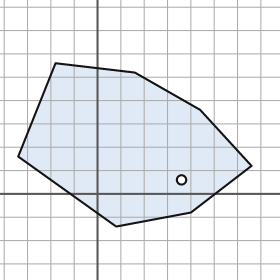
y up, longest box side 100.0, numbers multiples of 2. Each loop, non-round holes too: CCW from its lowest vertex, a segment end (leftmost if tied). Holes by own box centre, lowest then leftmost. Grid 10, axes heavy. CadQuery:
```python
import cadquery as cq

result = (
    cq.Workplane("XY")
    .moveTo(8.0, -14.0)
    .lineTo(40.0, -8.0)
    .lineTo(66.0, 12.0)
    .lineTo(44.0, 36.0)
    .lineTo(16.0, 52.0)
    .lineTo(-18.0, 56.0)
    .lineTo(-34.0, 16.0)
    .close()
    .moveTo(36.0, 6.0)
    .circle(2.0)
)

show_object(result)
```